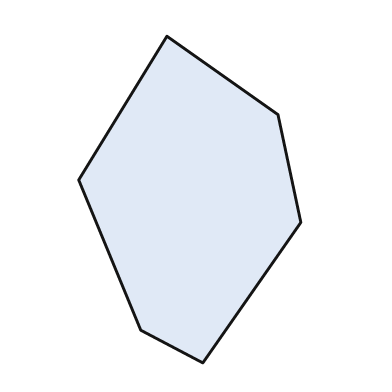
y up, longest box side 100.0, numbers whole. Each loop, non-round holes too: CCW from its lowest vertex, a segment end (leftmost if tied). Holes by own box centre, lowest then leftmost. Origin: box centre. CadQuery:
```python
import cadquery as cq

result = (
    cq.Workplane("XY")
    .moveTo(4.0, -50.0)
    .lineTo(34.0, -7.0)
    .lineTo(27.0, 26.0)
    .lineTo(-7.0, 50.0)
    .lineTo(-34.0, 6.0)
    .lineTo(-15.0, -40.0)
    .close()
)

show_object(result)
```